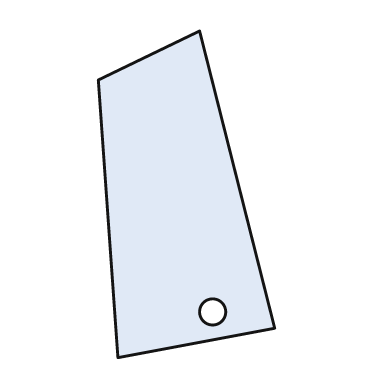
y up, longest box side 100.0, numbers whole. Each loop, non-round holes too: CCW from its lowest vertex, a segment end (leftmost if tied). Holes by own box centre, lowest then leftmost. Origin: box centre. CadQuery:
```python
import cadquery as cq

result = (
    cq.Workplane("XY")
    .moveTo(-21.0, -50.0)
    .lineTo(27.0, -41.0)
    .lineTo(4.0, 50.0)
    .lineTo(-27.0, 35.0)
    .close()
    .moveTo(8.0, -36.0)
    .circle(4.0)
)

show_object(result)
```